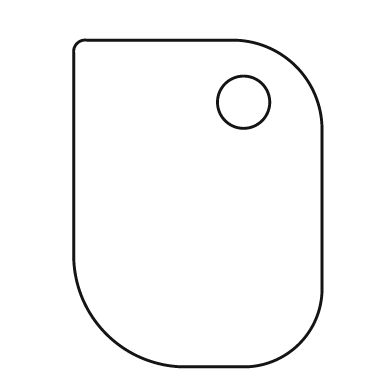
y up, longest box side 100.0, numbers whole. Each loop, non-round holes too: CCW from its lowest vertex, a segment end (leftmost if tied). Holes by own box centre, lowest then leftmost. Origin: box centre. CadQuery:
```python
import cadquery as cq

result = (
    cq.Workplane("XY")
    .moveTo(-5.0, -50.0)
    .lineTo(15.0, -50.0)
    .threePointArc((31.0, -43.0), (38.0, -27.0))
    .lineTo(38.0, 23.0)
    .threePointArc((30.0, 42.0), (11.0, 50.0))
    .lineTo(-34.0, 50.0)
    .threePointArc((-37.0, 49.0), (-38.0, 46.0))
    .lineTo(-38.0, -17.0)
    .threePointArc((-28.0, -40.0), (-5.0, -50.0))
    .close()
    .moveTo(14.0, 31.0)
    .circle(8.0)
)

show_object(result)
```